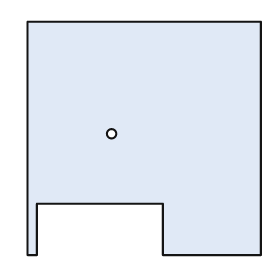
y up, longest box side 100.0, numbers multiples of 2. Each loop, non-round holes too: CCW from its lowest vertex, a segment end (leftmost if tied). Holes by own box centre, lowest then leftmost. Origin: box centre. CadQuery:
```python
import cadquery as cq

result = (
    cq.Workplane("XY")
    .moveTo(-50.0, -50.0)
    .lineTo(-46.0, -50.0)
    .lineTo(-46.0, -28.0)
    .lineTo(8.0, -28.0)
    .lineTo(8.0, -50.0)
    .lineTo(50.0, -50.0)
    .lineTo(50.0, 50.0)
    .lineTo(-50.0, 50.0)
    .close()
    .moveTo(-14.0, 2.0)
    .circle(2.0)
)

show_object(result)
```